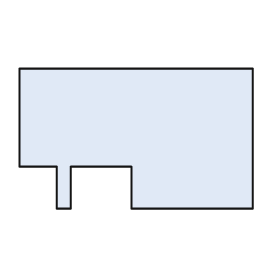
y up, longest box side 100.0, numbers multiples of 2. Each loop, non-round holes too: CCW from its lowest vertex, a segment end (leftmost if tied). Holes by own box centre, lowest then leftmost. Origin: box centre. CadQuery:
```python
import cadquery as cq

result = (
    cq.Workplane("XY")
    .moveTo(-34.0, -30.0)
    .lineTo(-28.0, -30.0)
    .lineTo(-28.0, -12.0)
    .lineTo(-2.0, -12.0)
    .lineTo(-2.0, -30.0)
    .lineTo(50.0, -30.0)
    .lineTo(50.0, 30.0)
    .lineTo(-50.0, 30.0)
    .lineTo(-50.0, -12.0)
    .lineTo(-34.0, -12.0)
    .close()
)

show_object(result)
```